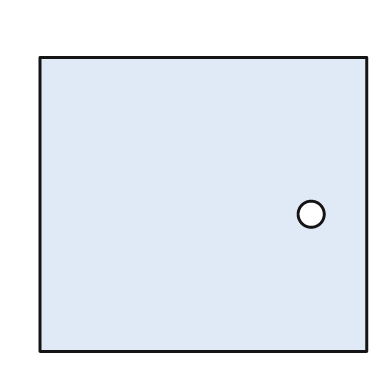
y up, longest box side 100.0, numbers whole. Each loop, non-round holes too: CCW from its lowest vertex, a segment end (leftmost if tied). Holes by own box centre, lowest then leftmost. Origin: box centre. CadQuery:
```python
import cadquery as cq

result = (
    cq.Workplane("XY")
    .moveTo(-50.0, -45.0)
    .lineTo(50.0, -45.0)
    .lineTo(50.0, 45.0)
    .lineTo(-50.0, 45.0)
    .close()
    .moveTo(33.0, -3.0)
    .circle(4.0)
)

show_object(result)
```